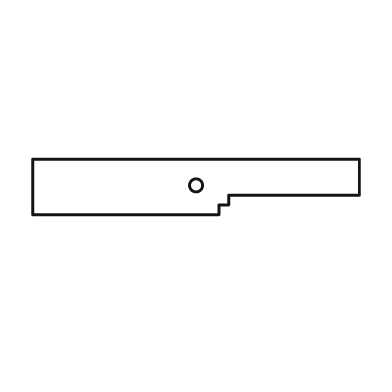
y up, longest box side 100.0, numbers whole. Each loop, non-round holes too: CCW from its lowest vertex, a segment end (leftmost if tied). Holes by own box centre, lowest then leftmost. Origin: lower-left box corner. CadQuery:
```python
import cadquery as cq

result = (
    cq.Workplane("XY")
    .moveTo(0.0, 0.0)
    .lineTo(57.0, 0.0)
    .lineTo(57.0, 3.0)
    .lineTo(60.0, 3.0)
    .lineTo(60.0, 6.0)
    .lineTo(100.0, 6.0)
    .lineTo(100.0, 17.0)
    .lineTo(0.0, 17.0)
    .close()
    .moveTo(50.0, 9.0)
    .circle(2.0)
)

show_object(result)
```